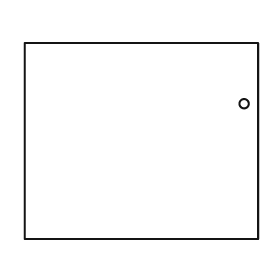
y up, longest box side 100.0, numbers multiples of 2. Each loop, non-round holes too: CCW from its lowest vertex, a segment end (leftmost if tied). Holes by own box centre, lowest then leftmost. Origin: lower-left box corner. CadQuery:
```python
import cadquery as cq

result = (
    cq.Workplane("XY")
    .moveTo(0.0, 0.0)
    .lineTo(100.0, 0.0)
    .lineTo(100.0, 84.0)
    .lineTo(0.0, 84.0)
    .close()
    .moveTo(94.0, 58.0)
    .circle(2.0)
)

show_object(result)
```